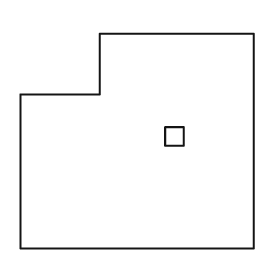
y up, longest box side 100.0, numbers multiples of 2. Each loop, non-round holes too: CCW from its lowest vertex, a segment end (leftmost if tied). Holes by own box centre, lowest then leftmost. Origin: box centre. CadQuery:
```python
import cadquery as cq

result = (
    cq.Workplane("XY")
    .moveTo(-50.0, -46.0)
    .lineTo(50.0, -46.0)
    .lineTo(50.0, 46.0)
    .lineTo(-16.0, 46.0)
    .lineTo(-16.0, 20.0)
    .lineTo(-50.0, 20.0)
    .close()
    .moveTo(12.0, -2.0)
    .lineTo(20.0, -2.0)
    .lineTo(20.0, 6.0)
    .lineTo(12.0, 6.0)
    .close()
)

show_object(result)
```